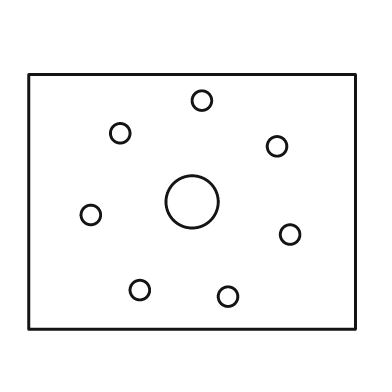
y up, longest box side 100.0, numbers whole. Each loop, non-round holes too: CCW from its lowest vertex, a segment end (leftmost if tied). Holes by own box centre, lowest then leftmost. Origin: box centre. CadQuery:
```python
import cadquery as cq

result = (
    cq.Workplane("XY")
    .moveTo(-50.0, -39.0)
    .lineTo(50.0, -39.0)
    .lineTo(50.0, 39.0)
    .lineTo(-50.0, 39.0)
    .close()
    .moveTo(11.0, -29.0)
    .circle(3.0)
    .moveTo(-16.0, -27.0)
    .circle(3.0)
    .moveTo(30.0, -10.0)
    .circle(3.0)
    .moveTo(-31.0, -4.0)
    .circle(3.0)
    .moveTo(0.0, 0.0)
    .circle(8.0)
    .moveTo(26.0, 17.0)
    .circle(3.0)
    .moveTo(-22.0, 21.0)
    .circle(3.0)
    .moveTo(3.0, 31.0)
    .circle(3.0)
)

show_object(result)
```